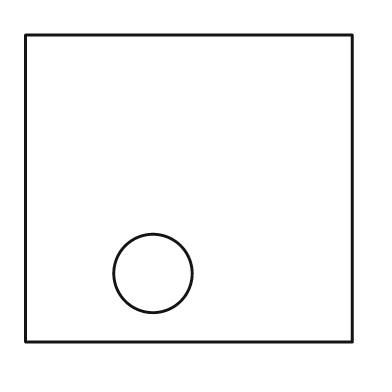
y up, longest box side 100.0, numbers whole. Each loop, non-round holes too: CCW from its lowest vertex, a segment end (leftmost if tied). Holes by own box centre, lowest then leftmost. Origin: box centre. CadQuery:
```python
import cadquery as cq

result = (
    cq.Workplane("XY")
    .moveTo(-50.0, -47.0)
    .lineTo(50.0, -47.0)
    .lineTo(50.0, 47.0)
    .lineTo(-50.0, 47.0)
    .close()
    .moveTo(-11.0, -26.0)
    .circle(12.0)
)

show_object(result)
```